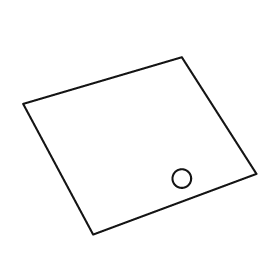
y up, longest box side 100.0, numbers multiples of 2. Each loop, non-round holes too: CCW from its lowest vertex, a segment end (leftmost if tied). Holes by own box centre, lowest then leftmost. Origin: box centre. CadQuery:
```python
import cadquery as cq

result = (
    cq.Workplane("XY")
    .moveTo(-20.0, -38.0)
    .lineTo(50.0, -12.0)
    .lineTo(18.0, 38.0)
    .lineTo(-50.0, 18.0)
    .close()
    .moveTo(18.0, -14.0)
    .circle(4.0)
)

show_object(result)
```